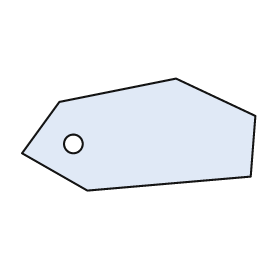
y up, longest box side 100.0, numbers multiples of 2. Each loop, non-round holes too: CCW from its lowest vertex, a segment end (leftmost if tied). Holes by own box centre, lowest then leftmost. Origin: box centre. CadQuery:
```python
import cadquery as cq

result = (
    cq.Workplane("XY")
    .moveTo(-22.0, -24.0)
    .lineTo(48.0, -18.0)
    .lineTo(50.0, 8.0)
    .lineTo(16.0, 24.0)
    .lineTo(-34.0, 14.0)
    .lineTo(-50.0, -8.0)
    .close()
    .moveTo(-28.0, -4.0)
    .circle(4.0)
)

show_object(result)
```